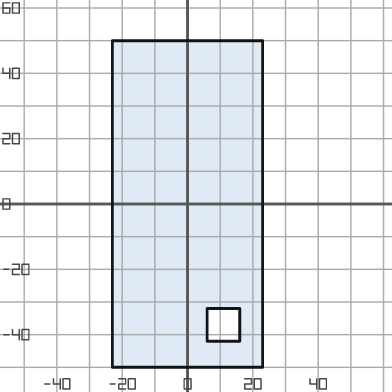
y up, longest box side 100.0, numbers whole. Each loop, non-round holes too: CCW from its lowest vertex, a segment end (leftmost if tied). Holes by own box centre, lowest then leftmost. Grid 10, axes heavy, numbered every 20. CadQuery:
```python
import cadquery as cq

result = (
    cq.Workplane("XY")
    .moveTo(-23.0, -50.0)
    .lineTo(23.0, -50.0)
    .lineTo(23.0, 50.0)
    .lineTo(-23.0, 50.0)
    .close()
    .moveTo(6.0, -42.0)
    .lineTo(16.0, -42.0)
    .lineTo(16.0, -32.0)
    .lineTo(6.0, -32.0)
    .close()
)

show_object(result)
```